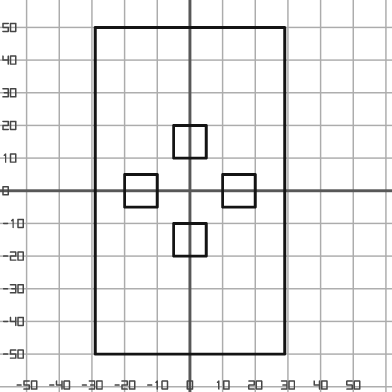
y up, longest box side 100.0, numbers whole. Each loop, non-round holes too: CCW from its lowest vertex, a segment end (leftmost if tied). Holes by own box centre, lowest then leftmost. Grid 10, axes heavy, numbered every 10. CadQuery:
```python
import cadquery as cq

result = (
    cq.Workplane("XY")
    .moveTo(-29.0, -50.0)
    .lineTo(29.0, -50.0)
    .lineTo(29.0, 50.0)
    .lineTo(-29.0, 50.0)
    .close()
    .moveTo(-5.0, -20.0)
    .lineTo(5.0, -20.0)
    .lineTo(5.0, -10.0)
    .lineTo(-5.0, -10.0)
    .close()
    .moveTo(-20.0, -5.0)
    .lineTo(-10.0, -5.0)
    .lineTo(-10.0, 5.0)
    .lineTo(-20.0, 5.0)
    .close()
    .moveTo(10.0, -5.0)
    .lineTo(20.0, -5.0)
    .lineTo(20.0, 5.0)
    .lineTo(10.0, 5.0)
    .close()
    .moveTo(-5.0, 10.0)
    .lineTo(5.0, 10.0)
    .lineTo(5.0, 20.0)
    .lineTo(-5.0, 20.0)
    .close()
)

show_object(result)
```